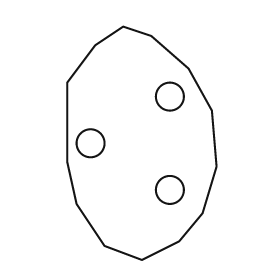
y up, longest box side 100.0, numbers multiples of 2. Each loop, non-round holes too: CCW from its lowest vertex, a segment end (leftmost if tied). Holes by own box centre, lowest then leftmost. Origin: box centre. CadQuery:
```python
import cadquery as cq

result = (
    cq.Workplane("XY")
    .moveTo(0.0, -50.0)
    .lineTo(16.0, -42.0)
    .lineTo(26.0, -30.0)
    .lineTo(32.0, -10.0)
    .lineTo(30.0, 14.0)
    .lineTo(20.0, 32.0)
    .lineTo(4.0, 46.0)
    .lineTo(-8.0, 50.0)
    .lineTo(-20.0, 42.0)
    .lineTo(-32.0, 26.0)
    .lineTo(-32.0, -8.0)
    .lineTo(-28.0, -26.0)
    .lineTo(-16.0, -44.0)
    .close()
    .moveTo(12.0, -20.0)
    .circle(6.0)
    .moveTo(-22.0, 0.0)
    .circle(6.0)
    .moveTo(12.0, 20.0)
    .circle(6.0)
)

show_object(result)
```